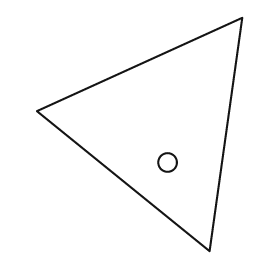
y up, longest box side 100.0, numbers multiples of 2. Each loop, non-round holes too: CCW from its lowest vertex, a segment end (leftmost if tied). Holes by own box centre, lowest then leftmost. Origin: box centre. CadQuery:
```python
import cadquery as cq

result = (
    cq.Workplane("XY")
    .moveTo(30.0, -50.0)
    .lineTo(44.0, 50.0)
    .lineTo(-44.0, 10.0)
    .close()
    .moveTo(12.0, -12.0)
    .circle(4.0)
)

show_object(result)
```